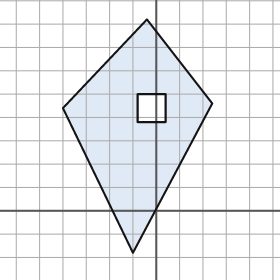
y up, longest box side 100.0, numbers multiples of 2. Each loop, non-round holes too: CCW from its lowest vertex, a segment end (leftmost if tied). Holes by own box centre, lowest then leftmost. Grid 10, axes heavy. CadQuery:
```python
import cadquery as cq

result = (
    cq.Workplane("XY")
    .moveTo(-10.0, -18.0)
    .lineTo(24.0, 46.0)
    .lineTo(-4.0, 82.0)
    .lineTo(-40.0, 44.0)
    .close()
    .moveTo(-8.0, 38.0)
    .lineTo(4.0, 38.0)
    .lineTo(4.0, 50.0)
    .lineTo(-8.0, 50.0)
    .close()
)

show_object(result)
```